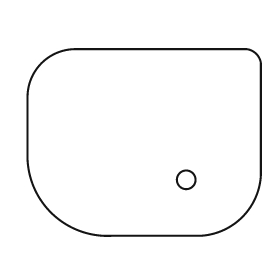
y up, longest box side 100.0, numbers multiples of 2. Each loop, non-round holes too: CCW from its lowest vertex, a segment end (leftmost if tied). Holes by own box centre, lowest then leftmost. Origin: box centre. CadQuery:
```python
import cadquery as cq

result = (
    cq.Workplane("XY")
    .moveTo(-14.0, -40.0)
    .lineTo(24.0, -40.0)
    .threePointArc((42.0, -32.0), (50.0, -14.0))
    .lineTo(50.0, 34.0)
    .threePointArc((48.0, 38.0), (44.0, 40.0))
    .lineTo(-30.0, 40.0)
    .threePointArc((-44.0, 34.0), (-50.0, 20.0))
    .lineTo(-50.0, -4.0)
    .threePointArc((-40.0, -30.0), (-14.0, -40.0))
    .close()
    .moveTo(18.0, -16.0)
    .circle(4.0)
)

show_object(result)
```